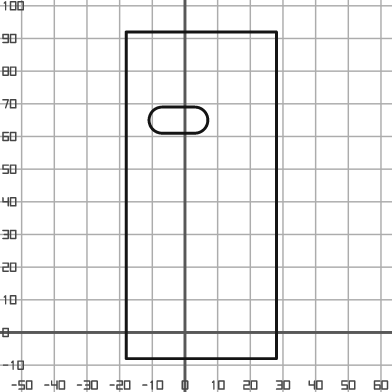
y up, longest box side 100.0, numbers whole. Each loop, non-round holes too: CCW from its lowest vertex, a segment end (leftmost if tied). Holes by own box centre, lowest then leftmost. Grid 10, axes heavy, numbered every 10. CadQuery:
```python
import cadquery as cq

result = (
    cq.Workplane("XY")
    .moveTo(-18.0, -8.0)
    .lineTo(28.0, -8.0)
    .lineTo(28.0, 92.0)
    .lineTo(-18.0, 92.0)
    .close()
    .moveTo(-7.0, 61.0)
    .lineTo(3.0, 61.0)
    .threePointArc((7.0, 65.0), (3.0, 69.0))
    .lineTo(-7.0, 69.0)
    .threePointArc((-11.0, 65.0), (-7.0, 61.0))
    .close()
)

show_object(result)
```